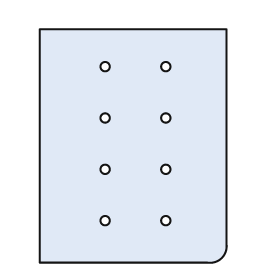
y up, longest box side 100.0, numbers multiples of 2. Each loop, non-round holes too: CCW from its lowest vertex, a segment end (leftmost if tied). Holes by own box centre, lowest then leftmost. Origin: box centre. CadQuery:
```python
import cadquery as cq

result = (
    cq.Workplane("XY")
    .moveTo(-40.0, -50.0)
    .lineTo(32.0, -50.0)
    .threePointArc((38.0, -48.0), (40.0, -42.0))
    .lineTo(40.0, 50.0)
    .lineTo(-40.0, 50.0)
    .close()
    .moveTo(-12.0, -32.0)
    .circle(2.0)
    .moveTo(14.0, -32.0)
    .circle(2.0)
    .moveTo(-12.0, -10.0)
    .circle(2.0)
    .moveTo(14.0, -10.0)
    .circle(2.0)
    .moveTo(-12.0, 12.0)
    .circle(2.0)
    .moveTo(14.0, 12.0)
    .circle(2.0)
    .moveTo(-12.0, 34.0)
    .circle(2.0)
    .moveTo(14.0, 34.0)
    .circle(2.0)
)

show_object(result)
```